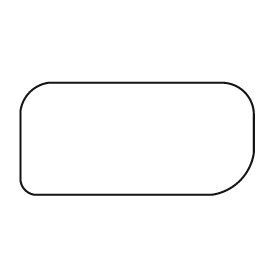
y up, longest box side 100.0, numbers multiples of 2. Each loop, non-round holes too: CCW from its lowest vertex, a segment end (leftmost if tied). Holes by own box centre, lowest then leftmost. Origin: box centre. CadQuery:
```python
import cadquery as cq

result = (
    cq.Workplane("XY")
    .moveTo(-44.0, -24.0)
    .lineTo(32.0, -24.0)
    .threePointArc((44.0, -18.0), (50.0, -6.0))
    .lineTo(50.0, 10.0)
    .threePointArc((46.0, 20.0), (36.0, 24.0))
    .lineTo(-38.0, 24.0)
    .threePointArc((-46.0, 20.0), (-50.0, 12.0))
    .lineTo(-50.0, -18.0)
    .threePointArc((-48.0, -22.0), (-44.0, -24.0))
    .close()
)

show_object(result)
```